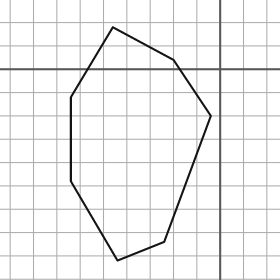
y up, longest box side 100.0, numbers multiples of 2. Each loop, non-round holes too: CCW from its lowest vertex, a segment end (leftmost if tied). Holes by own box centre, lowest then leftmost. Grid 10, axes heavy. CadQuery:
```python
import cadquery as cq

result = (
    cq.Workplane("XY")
    .moveTo(-44.0, -82.0)
    .lineTo(-24.0, -74.0)
    .lineTo(-4.0, -20.0)
    .lineTo(-20.0, 4.0)
    .lineTo(-46.0, 18.0)
    .lineTo(-64.0, -12.0)
    .lineTo(-64.0, -48.0)
    .close()
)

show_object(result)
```